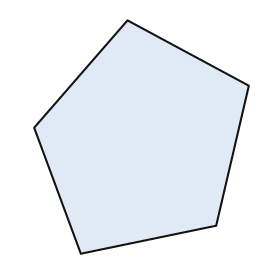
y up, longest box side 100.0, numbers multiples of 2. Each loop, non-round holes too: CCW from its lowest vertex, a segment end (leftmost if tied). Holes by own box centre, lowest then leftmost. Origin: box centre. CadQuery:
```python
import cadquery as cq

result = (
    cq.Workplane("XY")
    .moveTo(-26.0, -50.0)
    .lineTo(32.0, -38.0)
    .lineTo(46.0, 22.0)
    .lineTo(-6.0, 50.0)
    .lineTo(-46.0, 4.0)
    .close()
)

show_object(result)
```